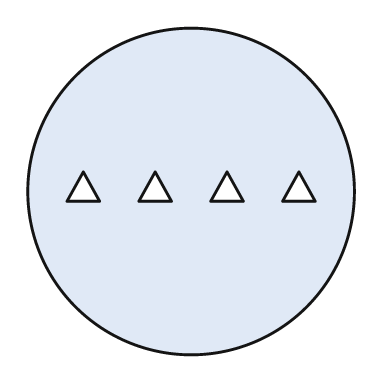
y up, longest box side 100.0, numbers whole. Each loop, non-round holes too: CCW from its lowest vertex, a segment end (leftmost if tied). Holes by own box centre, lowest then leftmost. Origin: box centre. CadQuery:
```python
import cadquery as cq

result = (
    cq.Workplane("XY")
    .moveTo(0.0, 0.0)
    .circle(50.0)
    .moveTo(-38.0, -3.0)
    .lineTo(-28.0, -3.0)
    .lineTo(-33.0, 6.0)
    .close()
    .moveTo(-16.0, -3.0)
    .lineTo(-6.0, -3.0)
    .lineTo(-11.0, 6.0)
    .close()
    .moveTo(6.0, -3.0)
    .lineTo(16.0, -3.0)
    .lineTo(11.0, 6.0)
    .close()
    .moveTo(28.0, -3.0)
    .lineTo(38.0, -3.0)
    .lineTo(33.0, 6.0)
    .close()
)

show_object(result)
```